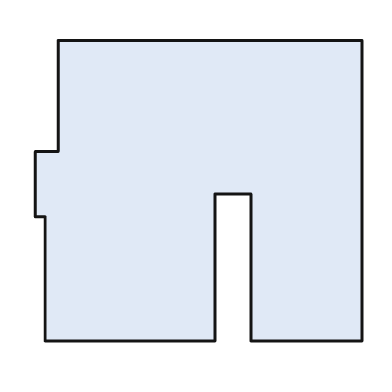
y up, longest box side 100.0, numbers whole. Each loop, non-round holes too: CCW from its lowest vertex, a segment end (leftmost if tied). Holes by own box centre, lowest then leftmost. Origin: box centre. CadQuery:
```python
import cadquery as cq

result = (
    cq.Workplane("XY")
    .moveTo(-47.0, -46.0)
    .lineTo(5.0, -46.0)
    .lineTo(5.0, -1.0)
    .lineTo(16.0, -1.0)
    .lineTo(16.0, -46.0)
    .lineTo(50.0, -46.0)
    .lineTo(50.0, 46.0)
    .lineTo(-43.0, 46.0)
    .lineTo(-43.0, 12.0)
    .lineTo(-50.0, 12.0)
    .lineTo(-50.0, -8.0)
    .lineTo(-47.0, -8.0)
    .close()
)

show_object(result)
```